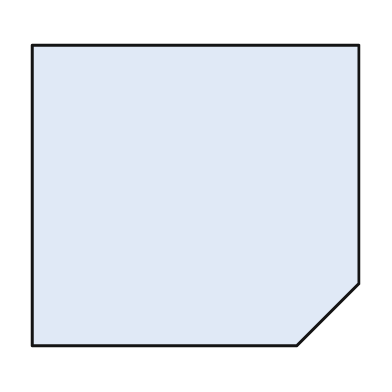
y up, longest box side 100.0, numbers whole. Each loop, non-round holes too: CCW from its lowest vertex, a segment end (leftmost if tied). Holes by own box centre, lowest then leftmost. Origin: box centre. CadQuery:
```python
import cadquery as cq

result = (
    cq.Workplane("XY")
    .moveTo(-50.0, -46.0)
    .lineTo(31.0, -46.0)
    .lineTo(50.0, -27.0)
    .lineTo(50.0, 46.0)
    .lineTo(-50.0, 46.0)
    .close()
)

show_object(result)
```